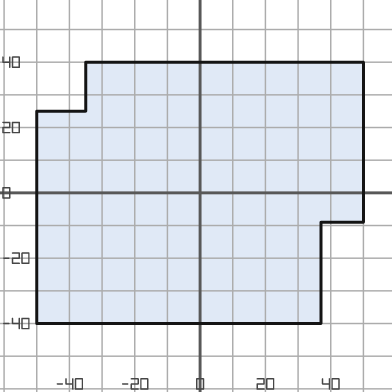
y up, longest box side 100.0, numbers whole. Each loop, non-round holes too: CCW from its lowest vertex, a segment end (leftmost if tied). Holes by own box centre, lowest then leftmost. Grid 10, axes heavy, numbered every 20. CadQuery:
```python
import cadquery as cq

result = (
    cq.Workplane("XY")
    .moveTo(-50.0, -40.0)
    .lineTo(37.0, -40.0)
    .lineTo(37.0, -9.0)
    .lineTo(50.0, -9.0)
    .lineTo(50.0, 40.0)
    .lineTo(-35.0, 40.0)
    .lineTo(-35.0, 25.0)
    .lineTo(-50.0, 25.0)
    .close()
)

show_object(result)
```